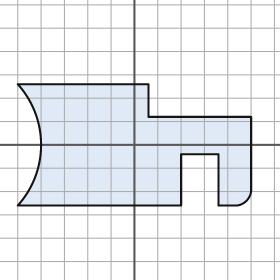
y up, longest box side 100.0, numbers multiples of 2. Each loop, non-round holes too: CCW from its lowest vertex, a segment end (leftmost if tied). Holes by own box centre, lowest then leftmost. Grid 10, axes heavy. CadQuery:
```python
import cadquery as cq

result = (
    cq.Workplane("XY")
    .moveTo(-50.0, -26.0)
    .lineTo(20.0, -26.0)
    .lineTo(20.0, -4.0)
    .lineTo(36.0, -4.0)
    .lineTo(36.0, -26.0)
    .lineTo(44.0, -26.0)
    .threePointArc((48.0, -24.0), (50.0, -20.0))
    .lineTo(50.0, 12.0)
    .lineTo(6.0, 12.0)
    .lineTo(6.0, 26.0)
    .lineTo(-50.0, 26.0)
    .threePointArc((-40.0, 0.0), (-50.0, -26.0))
    .close()
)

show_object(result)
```